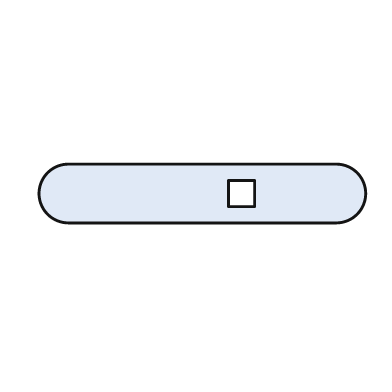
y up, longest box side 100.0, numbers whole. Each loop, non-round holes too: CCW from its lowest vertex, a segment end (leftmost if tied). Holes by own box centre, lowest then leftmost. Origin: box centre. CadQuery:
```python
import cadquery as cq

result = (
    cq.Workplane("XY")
    .moveTo(-41.0, -9.0)
    .lineTo(41.0, -9.0)
    .threePointArc((50.0, 0.0), (41.0, 9.0))
    .lineTo(-41.0, 9.0)
    .threePointArc((-50.0, 0.0), (-41.0, -9.0))
    .close()
    .moveTo(8.0, -4.0)
    .lineTo(16.0, -4.0)
    .lineTo(16.0, 4.0)
    .lineTo(8.0, 4.0)
    .close()
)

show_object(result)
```